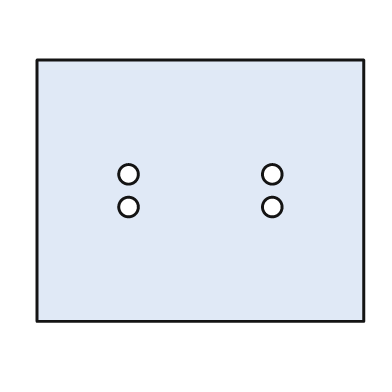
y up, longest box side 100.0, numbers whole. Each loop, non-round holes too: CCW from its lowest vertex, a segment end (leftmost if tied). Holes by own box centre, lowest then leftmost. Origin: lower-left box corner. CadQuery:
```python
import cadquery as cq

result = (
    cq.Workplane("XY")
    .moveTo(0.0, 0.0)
    .lineTo(100.0, 0.0)
    .lineTo(100.0, 80.0)
    .lineTo(0.0, 80.0)
    .close()
    .moveTo(28.0, 35.0)
    .circle(3.0)
    .moveTo(72.0, 35.0)
    .circle(3.0)
    .moveTo(28.0, 45.0)
    .circle(3.0)
    .moveTo(72.0, 45.0)
    .circle(3.0)
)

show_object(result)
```